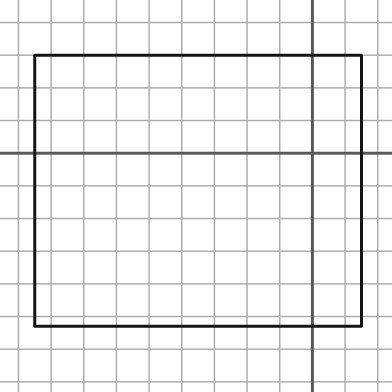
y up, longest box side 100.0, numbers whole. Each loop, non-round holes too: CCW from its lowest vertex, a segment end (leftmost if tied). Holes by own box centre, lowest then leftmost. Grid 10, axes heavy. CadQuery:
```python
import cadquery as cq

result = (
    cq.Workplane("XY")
    .moveTo(-85.0, -53.0)
    .lineTo(15.0, -53.0)
    .lineTo(15.0, 30.0)
    .lineTo(-85.0, 30.0)
    .close()
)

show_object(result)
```